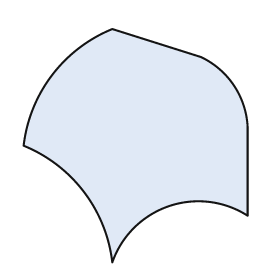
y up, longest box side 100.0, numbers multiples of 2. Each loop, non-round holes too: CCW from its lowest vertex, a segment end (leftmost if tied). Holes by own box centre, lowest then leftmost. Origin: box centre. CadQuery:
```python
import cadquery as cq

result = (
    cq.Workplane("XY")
    .moveTo(-10.0, -50.0)
    .threePointArc((14.0, -26.0), (48.0, -30.0))
    .lineTo(48.0, 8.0)
    .threePointArc((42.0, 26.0), (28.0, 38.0))
    .lineTo(-10.0, 50.0)
    .threePointArc((-36.0, 30.0), (-48.0, 0.0))
    .threePointArc((-22.0, -20.0), (-10.0, -50.0))
    .close()
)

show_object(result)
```